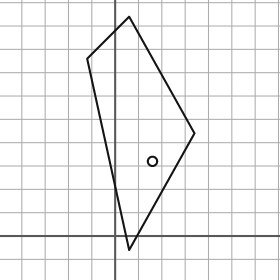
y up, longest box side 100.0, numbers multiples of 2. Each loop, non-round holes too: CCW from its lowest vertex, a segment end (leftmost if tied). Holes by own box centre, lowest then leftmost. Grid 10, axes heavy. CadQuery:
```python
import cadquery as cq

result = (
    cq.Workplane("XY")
    .moveTo(6.0, -6.0)
    .lineTo(34.0, 44.0)
    .lineTo(6.0, 94.0)
    .lineTo(-12.0, 76.0)
    .close()
    .moveTo(16.0, 32.0)
    .circle(2.0)
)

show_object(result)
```